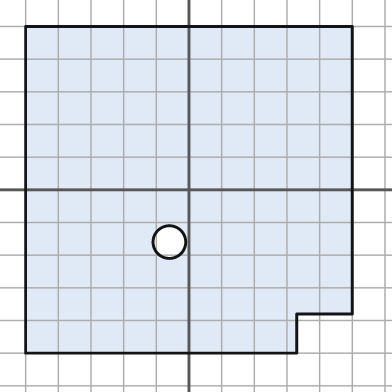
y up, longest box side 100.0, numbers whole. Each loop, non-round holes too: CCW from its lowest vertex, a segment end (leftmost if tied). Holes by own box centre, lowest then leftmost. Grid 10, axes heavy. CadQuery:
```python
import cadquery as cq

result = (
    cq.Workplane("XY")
    .moveTo(-50.0, -50.0)
    .lineTo(33.0, -50.0)
    .lineTo(33.0, -38.0)
    .lineTo(50.0, -38.0)
    .lineTo(50.0, 50.0)
    .lineTo(-50.0, 50.0)
    .close()
    .moveTo(-6.0, -16.0)
    .circle(5.0)
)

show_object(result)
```